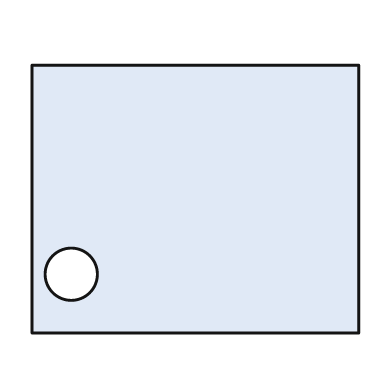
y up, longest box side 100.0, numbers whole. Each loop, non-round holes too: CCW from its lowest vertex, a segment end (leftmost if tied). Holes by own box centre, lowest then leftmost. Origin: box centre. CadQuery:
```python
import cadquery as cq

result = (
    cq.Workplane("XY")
    .moveTo(-50.0, -41.0)
    .lineTo(50.0, -41.0)
    .lineTo(50.0, 41.0)
    .lineTo(-50.0, 41.0)
    .close()
    .moveTo(-38.0, -23.0)
    .circle(8.0)
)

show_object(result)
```